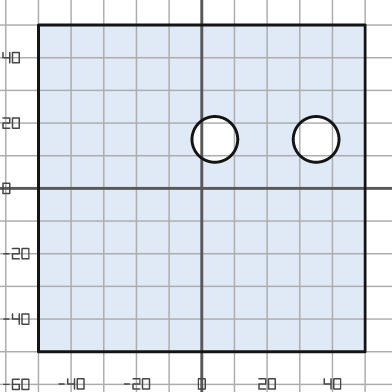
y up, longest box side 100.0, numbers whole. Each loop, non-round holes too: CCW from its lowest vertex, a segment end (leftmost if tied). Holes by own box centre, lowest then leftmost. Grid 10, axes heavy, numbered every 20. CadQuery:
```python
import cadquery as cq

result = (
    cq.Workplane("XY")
    .moveTo(-50.0, -50.0)
    .lineTo(50.0, -50.0)
    .lineTo(50.0, 50.0)
    .lineTo(-50.0, 50.0)
    .close()
    .moveTo(4.0, 15.0)
    .circle(7.0)
    .moveTo(35.0, 15.0)
    .circle(7.0)
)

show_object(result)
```